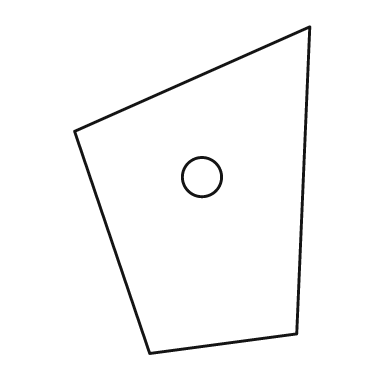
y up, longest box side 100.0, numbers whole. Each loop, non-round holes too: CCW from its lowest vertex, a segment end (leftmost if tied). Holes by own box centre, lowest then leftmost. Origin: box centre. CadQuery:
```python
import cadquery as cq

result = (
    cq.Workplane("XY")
    .moveTo(-13.0, -50.0)
    .lineTo(32.0, -44.0)
    .lineTo(36.0, 50.0)
    .lineTo(-36.0, 18.0)
    .close()
    .moveTo(3.0, 4.0)
    .circle(6.0)
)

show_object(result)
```